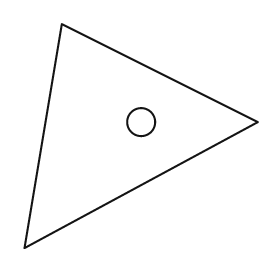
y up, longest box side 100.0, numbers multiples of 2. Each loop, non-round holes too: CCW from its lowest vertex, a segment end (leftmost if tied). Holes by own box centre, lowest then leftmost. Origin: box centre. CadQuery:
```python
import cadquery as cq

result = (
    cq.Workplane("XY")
    .moveTo(-50.0, -48.0)
    .lineTo(50.0, 6.0)
    .lineTo(-34.0, 48.0)
    .close()
    .moveTo(0.0, 6.0)
    .circle(6.0)
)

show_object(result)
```